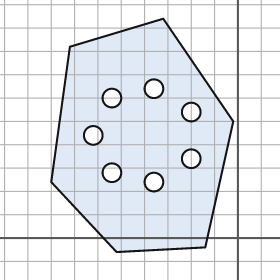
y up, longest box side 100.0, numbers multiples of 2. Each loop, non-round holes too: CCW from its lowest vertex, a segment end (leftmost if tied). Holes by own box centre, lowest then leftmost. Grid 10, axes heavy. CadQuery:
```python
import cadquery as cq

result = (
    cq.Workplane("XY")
    .moveTo(-52.0, -6.0)
    .lineTo(-14.0, -4.0)
    .lineTo(-2.0, 50.0)
    .lineTo(-32.0, 94.0)
    .lineTo(-72.0, 82.0)
    .lineTo(-80.0, 24.0)
    .close()
    .moveTo(-36.0, 24.0)
    .circle(4.0)
    .moveTo(-54.0, 28.0)
    .circle(4.0)
    .moveTo(-20.0, 34.0)
    .circle(4.0)
    .moveTo(-62.0, 44.0)
    .circle(4.0)
    .moveTo(-20.0, 54.0)
    .circle(4.0)
    .moveTo(-54.0, 60.0)
    .circle(4.0)
    .moveTo(-36.0, 64.0)
    .circle(4.0)
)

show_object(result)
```